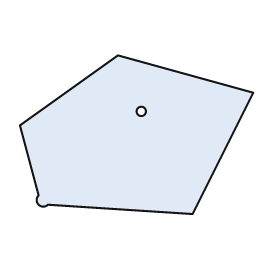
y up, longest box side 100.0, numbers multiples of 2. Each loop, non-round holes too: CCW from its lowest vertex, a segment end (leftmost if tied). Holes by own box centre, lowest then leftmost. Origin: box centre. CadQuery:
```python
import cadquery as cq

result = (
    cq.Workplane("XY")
    .moveTo(24.0, -34.0)
    .lineTo(50.0, 18.0)
    .lineTo(-8.0, 34.0)
    .lineTo(-50.0, 4.0)
    .lineTo(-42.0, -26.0)
    .threePointArc((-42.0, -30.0), (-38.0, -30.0))
    .close()
    .moveTo(2.0, 10.0)
    .circle(2.0)
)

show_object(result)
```